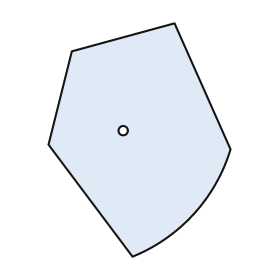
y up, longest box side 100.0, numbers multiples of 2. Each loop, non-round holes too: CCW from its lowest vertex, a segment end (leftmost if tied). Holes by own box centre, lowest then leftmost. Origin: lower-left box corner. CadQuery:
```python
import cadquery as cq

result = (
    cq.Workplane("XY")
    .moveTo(36.0, 0.0)
    .threePointArc((62.0, 18.0), (78.0, 46.0))
    .lineTo(54.0, 100.0)
    .lineTo(10.0, 88.0)
    .lineTo(0.0, 48.0)
    .close()
    .moveTo(32.0, 54.0)
    .circle(2.0)
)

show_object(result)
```